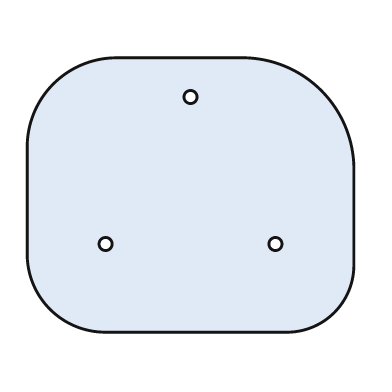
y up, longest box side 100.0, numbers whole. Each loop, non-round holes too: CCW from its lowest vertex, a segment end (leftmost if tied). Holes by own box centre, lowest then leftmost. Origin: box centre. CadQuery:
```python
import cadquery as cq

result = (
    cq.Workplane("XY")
    .moveTo(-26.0, -42.0)
    .lineTo(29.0, -42.0)
    .threePointArc((44.0, -36.0), (50.0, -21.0))
    .lineTo(50.0, 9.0)
    .threePointArc((40.0, 32.0), (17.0, 42.0))
    .lineTo(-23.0, 42.0)
    .threePointArc((-42.0, 34.0), (-50.0, 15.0))
    .lineTo(-50.0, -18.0)
    .threePointArc((-43.0, -35.0), (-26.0, -42.0))
    .close()
    .moveTo(-26.0, -15.0)
    .circle(2.0)
    .moveTo(26.0, -15.0)
    .circle(2.0)
    .moveTo(0.0, 30.0)
    .circle(2.0)
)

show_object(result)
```